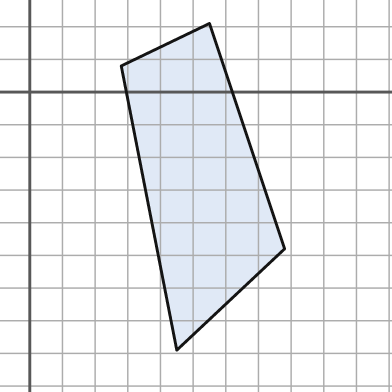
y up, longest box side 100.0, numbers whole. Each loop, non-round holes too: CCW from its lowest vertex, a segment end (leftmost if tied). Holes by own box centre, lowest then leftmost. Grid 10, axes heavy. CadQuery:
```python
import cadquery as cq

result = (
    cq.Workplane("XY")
    .moveTo(45.0, -79.0)
    .lineTo(78.0, -48.0)
    .lineTo(55.0, 21.0)
    .lineTo(28.0, 8.0)
    .close()
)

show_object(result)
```